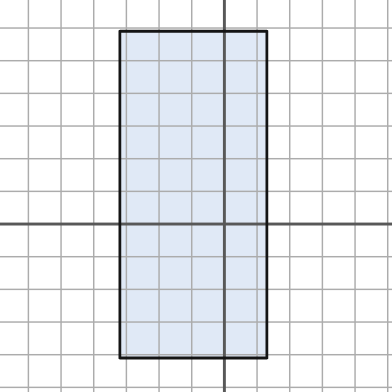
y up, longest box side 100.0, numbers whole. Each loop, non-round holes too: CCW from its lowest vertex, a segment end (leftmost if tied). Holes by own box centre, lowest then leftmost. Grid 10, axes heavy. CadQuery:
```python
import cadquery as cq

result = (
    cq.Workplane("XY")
    .moveTo(-32.0, -41.0)
    .lineTo(13.0, -41.0)
    .lineTo(13.0, 59.0)
    .lineTo(-32.0, 59.0)
    .close()
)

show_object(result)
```